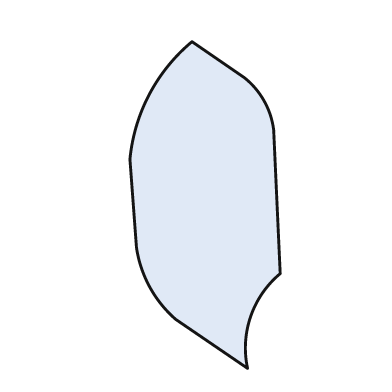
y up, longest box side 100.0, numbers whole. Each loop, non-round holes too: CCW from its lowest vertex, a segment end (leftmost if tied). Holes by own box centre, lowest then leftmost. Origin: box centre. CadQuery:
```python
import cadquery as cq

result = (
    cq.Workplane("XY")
    .moveTo(13.0, -50.0)
    .threePointArc((14.0, -34.0), (23.0, -21.0))
    .lineTo(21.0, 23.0)
    .threePointArc((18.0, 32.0), (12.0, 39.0))
    .lineTo(-4.0, 50.0)
    .threePointArc((-17.0, 34.0), (-23.0, 14.0))
    .lineTo(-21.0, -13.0)
    .threePointArc((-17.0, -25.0), (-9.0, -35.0))
    .close()
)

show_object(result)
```